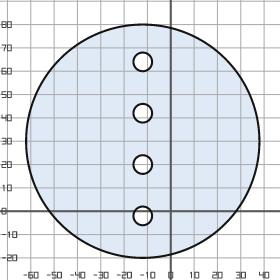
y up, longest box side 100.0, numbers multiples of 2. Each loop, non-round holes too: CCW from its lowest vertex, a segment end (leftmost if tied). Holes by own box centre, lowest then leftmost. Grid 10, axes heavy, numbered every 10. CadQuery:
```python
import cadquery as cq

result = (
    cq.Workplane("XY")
    .moveTo(-12.0, 30.0)
    .circle(50.0)
    .moveTo(-12.0, -2.0)
    .circle(4.0)
    .moveTo(-12.0, 20.0)
    .circle(4.0)
    .moveTo(-12.0, 42.0)
    .circle(4.0)
    .moveTo(-12.0, 64.0)
    .circle(4.0)
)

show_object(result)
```